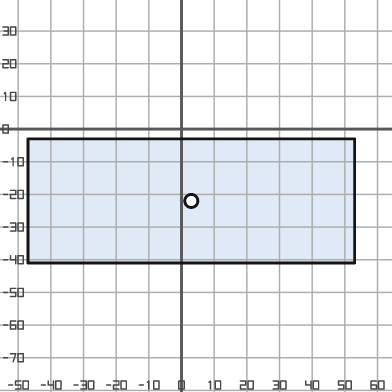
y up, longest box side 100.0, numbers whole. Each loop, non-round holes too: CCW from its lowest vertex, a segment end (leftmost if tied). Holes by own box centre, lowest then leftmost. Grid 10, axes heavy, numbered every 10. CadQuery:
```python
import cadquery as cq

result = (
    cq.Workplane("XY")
    .moveTo(-47.0, -41.0)
    .lineTo(53.0, -41.0)
    .lineTo(53.0, -3.0)
    .lineTo(-47.0, -3.0)
    .close()
    .moveTo(3.0, -22.0)
    .circle(2.0)
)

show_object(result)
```